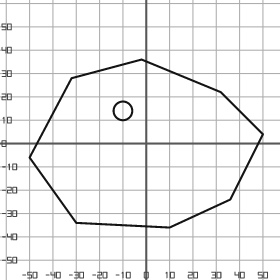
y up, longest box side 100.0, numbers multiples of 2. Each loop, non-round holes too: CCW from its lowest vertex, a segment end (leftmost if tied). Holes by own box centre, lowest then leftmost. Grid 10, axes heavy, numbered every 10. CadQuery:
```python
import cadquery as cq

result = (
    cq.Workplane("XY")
    .moveTo(10.0, -36.0)
    .lineTo(36.0, -24.0)
    .lineTo(50.0, 4.0)
    .lineTo(32.0, 22.0)
    .lineTo(-2.0, 36.0)
    .lineTo(-32.0, 28.0)
    .lineTo(-50.0, -6.0)
    .lineTo(-30.0, -34.0)
    .close()
    .moveTo(-10.0, 14.0)
    .circle(4.0)
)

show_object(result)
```